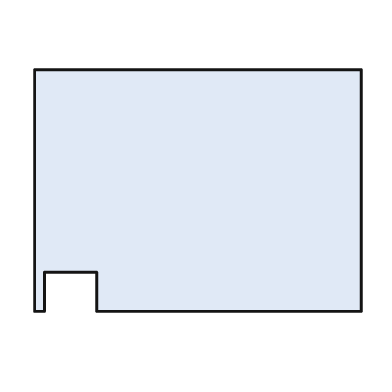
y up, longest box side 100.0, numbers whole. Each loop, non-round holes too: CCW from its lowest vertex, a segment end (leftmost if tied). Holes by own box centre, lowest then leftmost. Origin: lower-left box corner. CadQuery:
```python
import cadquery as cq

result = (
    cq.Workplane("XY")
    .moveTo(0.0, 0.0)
    .lineTo(3.0, 0.0)
    .lineTo(3.0, 12.0)
    .lineTo(19.0, 12.0)
    .lineTo(19.0, 0.0)
    .lineTo(100.0, 0.0)
    .lineTo(100.0, 74.0)
    .lineTo(0.0, 74.0)
    .close()
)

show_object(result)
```